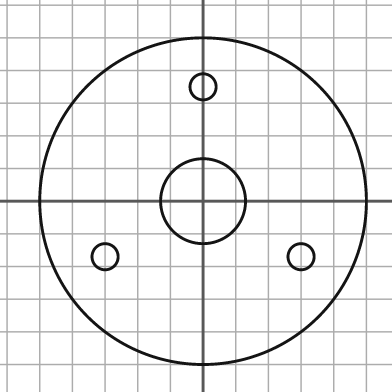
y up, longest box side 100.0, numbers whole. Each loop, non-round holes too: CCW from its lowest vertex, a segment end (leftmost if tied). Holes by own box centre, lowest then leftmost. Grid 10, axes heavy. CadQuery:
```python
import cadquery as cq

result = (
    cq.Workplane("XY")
    .moveTo(0.0, 0.0)
    .circle(50.0)
    .moveTo(-30.0, -17.0)
    .circle(4.0)
    .moveTo(30.0, -17.0)
    .circle(4.0)
    .moveTo(0.0, 0.0)
    .circle(13.0)
    .moveTo(0.0, 35.0)
    .circle(4.0)
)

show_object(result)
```